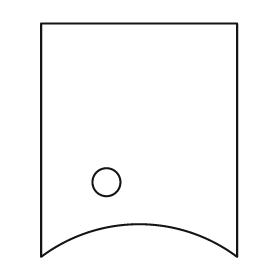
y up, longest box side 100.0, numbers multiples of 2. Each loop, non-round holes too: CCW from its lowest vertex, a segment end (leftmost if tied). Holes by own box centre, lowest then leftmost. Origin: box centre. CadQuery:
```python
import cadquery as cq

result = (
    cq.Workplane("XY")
    .moveTo(-42.0, -50.0)
    .threePointArc((0.0, -36.0), (42.0, -50.0))
    .lineTo(42.0, 50.0)
    .lineTo(-42.0, 50.0)
    .close()
    .moveTo(-14.0, -18.0)
    .circle(6.0)
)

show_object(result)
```